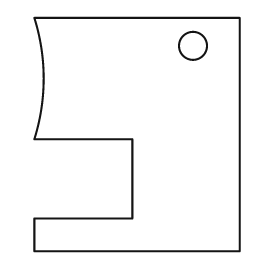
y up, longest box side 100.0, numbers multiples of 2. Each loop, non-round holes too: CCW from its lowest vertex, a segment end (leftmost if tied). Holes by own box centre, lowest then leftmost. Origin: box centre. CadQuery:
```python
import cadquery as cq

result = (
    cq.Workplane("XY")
    .moveTo(-44.0, -50.0)
    .lineTo(44.0, -50.0)
    .lineTo(44.0, 50.0)
    .lineTo(-44.0, 50.0)
    .threePointArc((-40.0, 24.0), (-44.0, -2.0))
    .lineTo(-2.0, -2.0)
    .lineTo(-2.0, -36.0)
    .lineTo(-44.0, -36.0)
    .close()
    .moveTo(24.0, 38.0)
    .circle(6.0)
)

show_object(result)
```